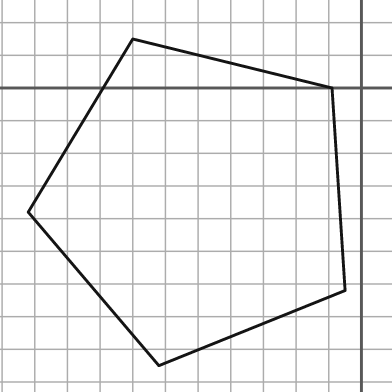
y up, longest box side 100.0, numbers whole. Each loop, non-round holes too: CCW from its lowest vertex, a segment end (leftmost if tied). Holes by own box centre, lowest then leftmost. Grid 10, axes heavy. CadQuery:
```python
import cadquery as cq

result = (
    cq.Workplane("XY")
    .moveTo(-62.0, -85.0)
    .lineTo(-5.0, -62.0)
    .lineTo(-9.0, 0.0)
    .lineTo(-70.0, 15.0)
    .lineTo(-102.0, -38.0)
    .close()
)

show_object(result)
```